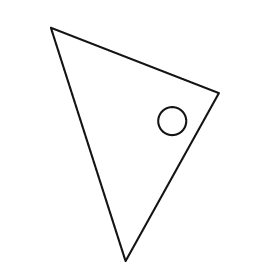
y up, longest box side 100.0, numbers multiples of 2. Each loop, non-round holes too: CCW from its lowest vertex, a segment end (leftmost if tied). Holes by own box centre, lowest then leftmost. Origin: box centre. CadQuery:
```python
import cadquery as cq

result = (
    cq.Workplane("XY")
    .moveTo(-4.0, -50.0)
    .lineTo(36.0, 22.0)
    .lineTo(-36.0, 50.0)
    .close()
    .moveTo(16.0, 10.0)
    .circle(6.0)
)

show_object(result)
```